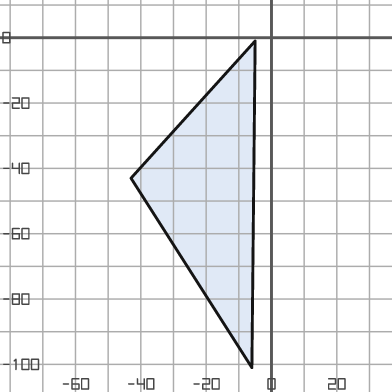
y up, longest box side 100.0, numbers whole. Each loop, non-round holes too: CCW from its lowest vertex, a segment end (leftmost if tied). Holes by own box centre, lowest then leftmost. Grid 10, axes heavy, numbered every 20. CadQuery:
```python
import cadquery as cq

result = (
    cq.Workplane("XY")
    .moveTo(-6.0, -101.0)
    .lineTo(-5.0, -1.0)
    .lineTo(-43.0, -43.0)
    .close()
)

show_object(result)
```